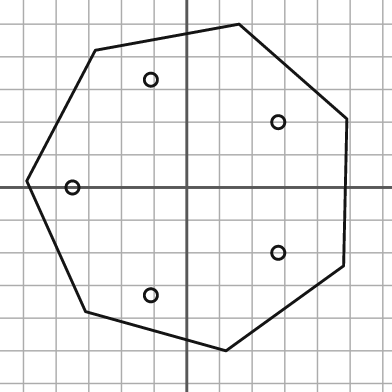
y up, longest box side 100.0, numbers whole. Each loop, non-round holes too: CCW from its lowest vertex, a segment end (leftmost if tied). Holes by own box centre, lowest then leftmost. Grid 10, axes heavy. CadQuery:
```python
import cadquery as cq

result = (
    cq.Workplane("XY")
    .moveTo(12.0, -50.0)
    .lineTo(48.0, -24.0)
    .lineTo(49.0, 21.0)
    .lineTo(16.0, 50.0)
    .lineTo(-28.0, 42.0)
    .lineTo(-49.0, 2.0)
    .lineTo(-31.0, -38.0)
    .close()
    .moveTo(-11.0, -33.0)
    .circle(2.0)
    .moveTo(28.0, -20.0)
    .circle(2.0)
    .moveTo(-35.0, 0.0)
    .circle(2.0)
    .moveTo(28.0, 20.0)
    .circle(2.0)
    .moveTo(-11.0, 33.0)
    .circle(2.0)
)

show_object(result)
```